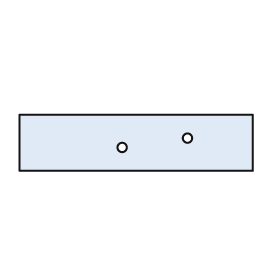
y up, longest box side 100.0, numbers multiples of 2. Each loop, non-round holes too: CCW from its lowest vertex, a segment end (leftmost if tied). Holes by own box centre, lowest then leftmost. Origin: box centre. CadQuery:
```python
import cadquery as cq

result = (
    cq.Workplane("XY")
    .moveTo(-50.0, -12.0)
    .lineTo(50.0, -12.0)
    .lineTo(50.0, 12.0)
    .lineTo(-50.0, 12.0)
    .close()
    .moveTo(-6.0, -2.0)
    .circle(2.0)
    .moveTo(22.0, 2.0)
    .circle(2.0)
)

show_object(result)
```